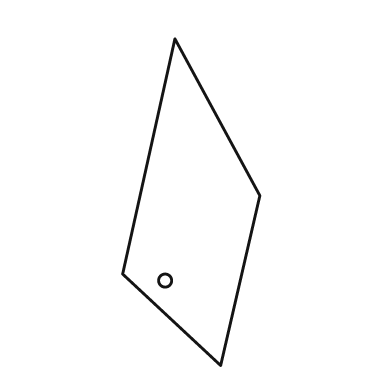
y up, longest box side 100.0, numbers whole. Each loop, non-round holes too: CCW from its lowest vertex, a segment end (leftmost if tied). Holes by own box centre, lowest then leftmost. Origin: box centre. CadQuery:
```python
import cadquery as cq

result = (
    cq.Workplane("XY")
    .moveTo(9.0, -50.0)
    .lineTo(21.0, 2.0)
    .lineTo(-5.0, 50.0)
    .lineTo(-21.0, -22.0)
    .close()
    .moveTo(-8.0, -24.0)
    .circle(2.0)
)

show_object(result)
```